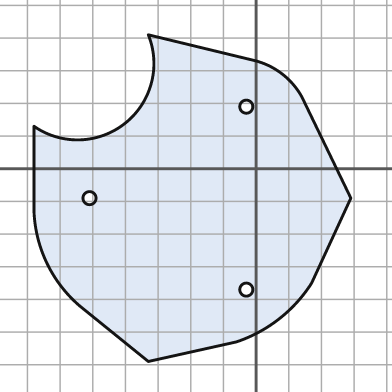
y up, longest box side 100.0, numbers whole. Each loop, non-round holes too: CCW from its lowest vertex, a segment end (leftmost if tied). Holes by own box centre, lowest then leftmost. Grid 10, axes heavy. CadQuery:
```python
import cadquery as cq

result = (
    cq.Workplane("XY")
    .moveTo(-33.0, -59.0)
    .lineTo(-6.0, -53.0)
    .threePointArc((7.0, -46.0), (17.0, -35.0))
    .lineTo(29.0, -9.0)
    .lineTo(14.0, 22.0)
    .threePointArc((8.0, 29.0), (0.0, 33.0))
    .lineTo(-33.0, 41.0)
    .threePointArc((-40.0, 14.0), (-68.0, 13.0))
    .lineTo(-68.0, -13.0)
    .threePointArc((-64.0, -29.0), (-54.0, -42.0))
    .close()
    .moveTo(-3.0, -37.0)
    .circle(2.0)
    .moveTo(-51.0, -9.0)
    .circle(2.0)
    .moveTo(-3.0, 19.0)
    .circle(2.0)
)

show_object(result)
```